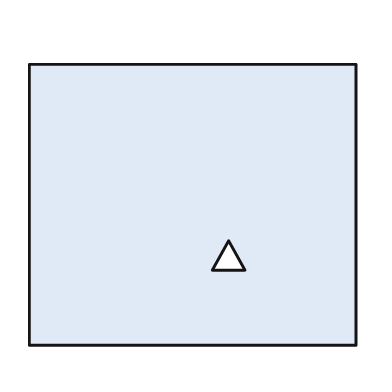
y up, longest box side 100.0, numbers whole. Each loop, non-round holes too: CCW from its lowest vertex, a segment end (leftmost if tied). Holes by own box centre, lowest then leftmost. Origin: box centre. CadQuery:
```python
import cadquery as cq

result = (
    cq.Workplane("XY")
    .moveTo(-50.0, -43.0)
    .lineTo(50.0, -43.0)
    .lineTo(50.0, 43.0)
    .lineTo(-50.0, 43.0)
    .close()
    .moveTo(6.0, -20.0)
    .lineTo(16.0, -20.0)
    .lineTo(11.0, -11.0)
    .close()
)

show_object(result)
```